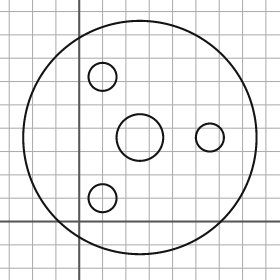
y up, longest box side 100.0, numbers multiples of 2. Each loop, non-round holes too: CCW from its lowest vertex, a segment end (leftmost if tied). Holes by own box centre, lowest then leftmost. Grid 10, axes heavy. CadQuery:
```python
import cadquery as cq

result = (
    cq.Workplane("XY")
    .moveTo(26.0, 36.0)
    .circle(50.0)
    .moveTo(10.0, 10.0)
    .circle(6.0)
    .moveTo(26.0, 36.0)
    .circle(10.0)
    .moveTo(56.0, 36.0)
    .circle(6.0)
    .moveTo(10.0, 62.0)
    .circle(6.0)
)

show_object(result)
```